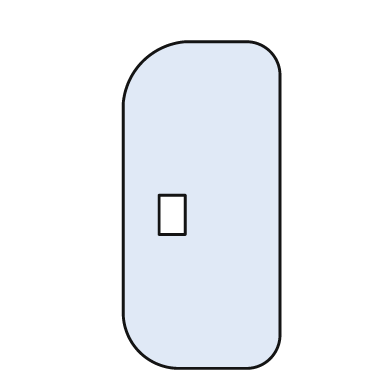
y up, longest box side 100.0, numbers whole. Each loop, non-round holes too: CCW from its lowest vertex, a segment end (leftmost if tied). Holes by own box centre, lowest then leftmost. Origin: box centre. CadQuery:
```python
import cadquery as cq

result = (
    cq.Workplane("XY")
    .moveTo(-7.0, -50.0)
    .lineTo(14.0, -50.0)
    .threePointArc((21.0, -47.0), (24.0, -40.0))
    .lineTo(24.0, 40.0)
    .threePointArc((21.0, 47.0), (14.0, 50.0))
    .lineTo(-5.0, 50.0)
    .threePointArc((-18.0, 44.0), (-24.0, 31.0))
    .lineTo(-24.0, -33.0)
    .threePointArc((-19.0, -45.0), (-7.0, -50.0))
    .close()
    .moveTo(-13.0, -9.0)
    .lineTo(-5.0, -9.0)
    .lineTo(-5.0, 3.0)
    .lineTo(-13.0, 3.0)
    .close()
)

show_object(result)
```